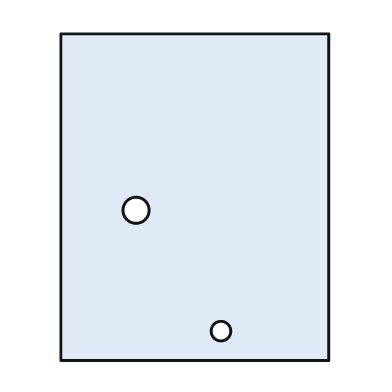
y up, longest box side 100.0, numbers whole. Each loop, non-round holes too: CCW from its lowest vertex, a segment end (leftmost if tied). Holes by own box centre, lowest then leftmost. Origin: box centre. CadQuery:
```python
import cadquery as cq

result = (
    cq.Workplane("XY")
    .moveTo(-41.0, -50.0)
    .lineTo(41.0, -50.0)
    .lineTo(41.0, 50.0)
    .lineTo(-41.0, 50.0)
    .close()
    .moveTo(8.0, -41.0)
    .circle(3.0)
    .moveTo(-18.0, -4.0)
    .circle(4.0)
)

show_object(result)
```